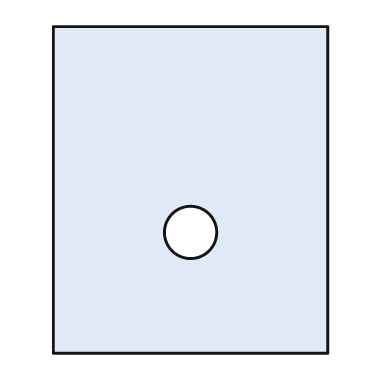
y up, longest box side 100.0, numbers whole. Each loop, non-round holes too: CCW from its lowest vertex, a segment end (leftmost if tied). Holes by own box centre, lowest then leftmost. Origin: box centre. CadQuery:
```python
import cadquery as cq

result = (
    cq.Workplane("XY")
    .moveTo(-42.0, -50.0)
    .lineTo(42.0, -50.0)
    .lineTo(42.0, 50.0)
    .lineTo(-42.0, 50.0)
    .close()
    .moveTo(0.0, -13.0)
    .circle(8.0)
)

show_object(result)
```